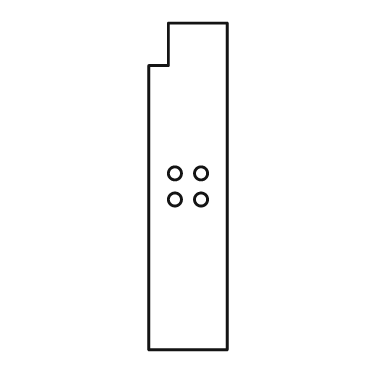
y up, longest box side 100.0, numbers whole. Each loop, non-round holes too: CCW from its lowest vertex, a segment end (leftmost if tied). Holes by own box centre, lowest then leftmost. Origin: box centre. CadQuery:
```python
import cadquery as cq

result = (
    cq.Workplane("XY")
    .moveTo(-12.0, -50.0)
    .lineTo(12.0, -50.0)
    .lineTo(12.0, 50.0)
    .lineTo(-6.0, 50.0)
    .lineTo(-6.0, 37.0)
    .lineTo(-12.0, 37.0)
    .close()
    .moveTo(-4.0, -4.0)
    .circle(2.0)
    .moveTo(4.0, -4.0)
    .circle(2.0)
    .moveTo(-4.0, 4.0)
    .circle(2.0)
    .moveTo(4.0, 4.0)
    .circle(2.0)
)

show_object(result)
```